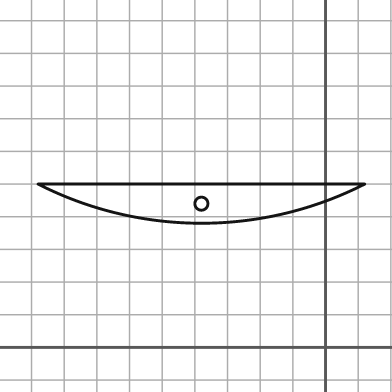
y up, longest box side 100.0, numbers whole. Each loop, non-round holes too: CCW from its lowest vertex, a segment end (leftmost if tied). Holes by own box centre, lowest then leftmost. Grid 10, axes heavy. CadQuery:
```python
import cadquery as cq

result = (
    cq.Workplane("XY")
    .moveTo(-88.0, 50.0)
    .threePointArc((-38.0, 38.0), (12.0, 50.0))
    .close()
    .moveTo(-38.0, 44.0)
    .circle(2.0)
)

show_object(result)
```